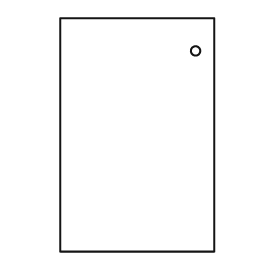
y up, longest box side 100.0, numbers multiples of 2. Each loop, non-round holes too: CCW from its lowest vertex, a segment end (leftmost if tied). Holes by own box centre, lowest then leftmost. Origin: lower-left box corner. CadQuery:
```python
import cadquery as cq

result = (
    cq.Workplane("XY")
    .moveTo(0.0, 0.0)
    .lineTo(66.0, 0.0)
    .lineTo(66.0, 100.0)
    .lineTo(0.0, 100.0)
    .close()
    .moveTo(58.0, 86.0)
    .circle(2.0)
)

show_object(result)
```